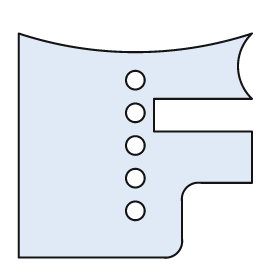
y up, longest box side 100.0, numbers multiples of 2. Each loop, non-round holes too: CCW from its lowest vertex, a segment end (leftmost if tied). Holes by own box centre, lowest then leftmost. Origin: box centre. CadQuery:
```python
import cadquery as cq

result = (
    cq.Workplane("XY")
    .moveTo(-50.0, -48.0)
    .lineTo(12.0, -48.0)
    .threePointArc((18.0, -46.0), (20.0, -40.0))
    .lineTo(20.0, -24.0)
    .threePointArc((22.0, -18.0), (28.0, -16.0))
    .lineTo(50.0, -16.0)
    .lineTo(50.0, 6.0)
    .lineTo(8.0, 6.0)
    .lineTo(8.0, 20.0)
    .lineTo(50.0, 20.0)
    .threePointArc((44.0, 34.0), (50.0, 48.0))
    .threePointArc((0.0, 40.0), (-50.0, 48.0))
    .close()
    .moveTo(0.0, -28.0)
    .circle(4.0)
    .moveTo(0.0, -14.0)
    .circle(4.0)
    .moveTo(0.0, 0.0)
    .circle(4.0)
    .moveTo(0.0, 14.0)
    .circle(4.0)
    .moveTo(0.0, 28.0)
    .circle(4.0)
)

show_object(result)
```